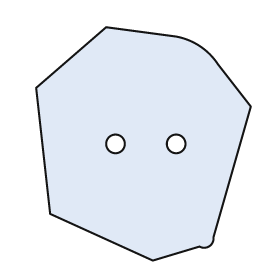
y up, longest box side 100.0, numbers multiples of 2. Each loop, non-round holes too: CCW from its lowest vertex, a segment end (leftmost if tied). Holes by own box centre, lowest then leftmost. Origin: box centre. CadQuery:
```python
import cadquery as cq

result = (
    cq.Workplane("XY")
    .moveTo(4.0, -50.0)
    .lineTo(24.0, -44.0)
    .threePointArc((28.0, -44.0), (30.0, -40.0))
    .lineTo(46.0, 16.0)
    .lineTo(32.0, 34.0)
    .threePointArc((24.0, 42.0), (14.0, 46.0))
    .lineTo(-16.0, 50.0)
    .lineTo(-46.0, 24.0)
    .lineTo(-40.0, -30.0)
    .close()
    .moveTo(-12.0, 0.0)
    .circle(4.0)
    .moveTo(14.0, 0.0)
    .circle(4.0)
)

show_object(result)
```